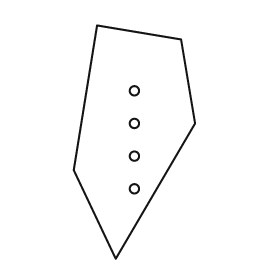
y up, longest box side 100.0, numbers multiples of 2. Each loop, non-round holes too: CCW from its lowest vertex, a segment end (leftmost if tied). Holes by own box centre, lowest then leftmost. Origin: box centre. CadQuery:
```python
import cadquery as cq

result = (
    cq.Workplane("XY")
    .moveTo(-8.0, -50.0)
    .lineTo(26.0, 8.0)
    .lineTo(20.0, 44.0)
    .lineTo(-16.0, 50.0)
    .lineTo(-26.0, -12.0)
    .close()
    .moveTo(0.0, -20.0)
    .circle(2.0)
    .moveTo(0.0, -6.0)
    .circle(2.0)
    .moveTo(0.0, 8.0)
    .circle(2.0)
    .moveTo(0.0, 22.0)
    .circle(2.0)
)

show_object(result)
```